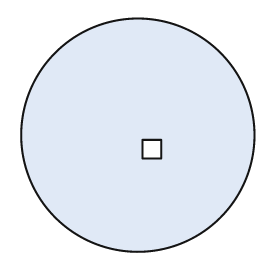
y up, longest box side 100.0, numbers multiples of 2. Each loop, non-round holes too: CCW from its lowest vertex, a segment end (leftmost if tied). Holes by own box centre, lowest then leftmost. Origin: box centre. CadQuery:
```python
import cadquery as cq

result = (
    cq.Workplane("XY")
    .moveTo(0.0, 0.0)
    .circle(50.0)
    .moveTo(2.0, -10.0)
    .lineTo(10.0, -10.0)
    .lineTo(10.0, -2.0)
    .lineTo(2.0, -2.0)
    .close()
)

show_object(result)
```